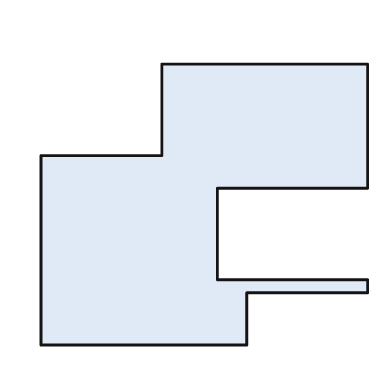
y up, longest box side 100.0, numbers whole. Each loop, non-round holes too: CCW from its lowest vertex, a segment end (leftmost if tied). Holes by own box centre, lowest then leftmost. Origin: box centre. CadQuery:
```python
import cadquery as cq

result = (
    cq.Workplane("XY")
    .moveTo(-50.0, -43.0)
    .lineTo(13.0, -43.0)
    .lineTo(13.0, -27.0)
    .lineTo(50.0, -27.0)
    .lineTo(50.0, -23.0)
    .lineTo(4.0, -23.0)
    .lineTo(4.0, 5.0)
    .lineTo(50.0, 5.0)
    .lineTo(50.0, 43.0)
    .lineTo(-13.0, 43.0)
    .lineTo(-13.0, 15.0)
    .lineTo(-50.0, 15.0)
    .close()
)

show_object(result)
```